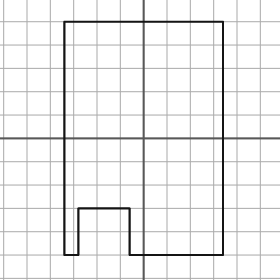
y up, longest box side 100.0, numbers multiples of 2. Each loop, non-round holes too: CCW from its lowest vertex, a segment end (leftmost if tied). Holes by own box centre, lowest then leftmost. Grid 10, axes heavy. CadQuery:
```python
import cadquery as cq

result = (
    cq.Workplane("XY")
    .moveTo(-34.0, -50.0)
    .lineTo(-28.0, -50.0)
    .lineTo(-28.0, -30.0)
    .lineTo(-6.0, -30.0)
    .lineTo(-6.0, -50.0)
    .lineTo(34.0, -50.0)
    .lineTo(34.0, 50.0)
    .lineTo(-34.0, 50.0)
    .close()
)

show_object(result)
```